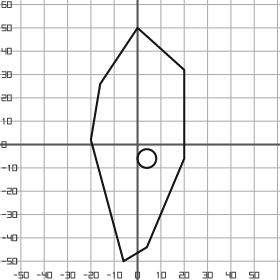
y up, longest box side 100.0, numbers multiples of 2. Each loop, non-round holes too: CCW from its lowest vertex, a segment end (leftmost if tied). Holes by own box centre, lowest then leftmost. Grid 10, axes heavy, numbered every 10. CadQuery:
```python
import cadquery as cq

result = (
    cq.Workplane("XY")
    .moveTo(-6.0, -50.0)
    .lineTo(4.0, -44.0)
    .lineTo(20.0, -6.0)
    .lineTo(20.0, 32.0)
    .lineTo(0.0, 50.0)
    .lineTo(-16.0, 26.0)
    .lineTo(-20.0, 2.0)
    .close()
    .moveTo(4.0, -6.0)
    .circle(4.0)
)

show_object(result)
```